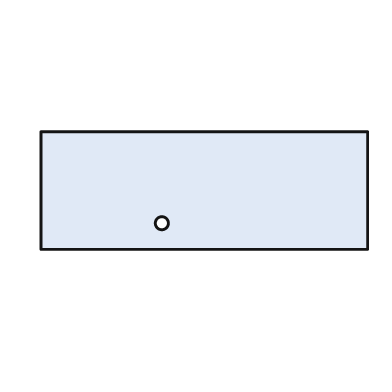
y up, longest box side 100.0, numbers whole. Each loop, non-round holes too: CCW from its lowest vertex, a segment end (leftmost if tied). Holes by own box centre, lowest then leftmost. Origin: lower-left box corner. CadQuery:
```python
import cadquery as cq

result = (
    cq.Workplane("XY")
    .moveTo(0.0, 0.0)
    .lineTo(100.0, 0.0)
    .lineTo(100.0, 36.0)
    .lineTo(0.0, 36.0)
    .close()
    .moveTo(37.0, 8.0)
    .circle(2.0)
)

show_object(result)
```